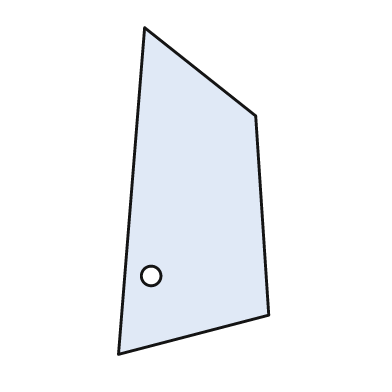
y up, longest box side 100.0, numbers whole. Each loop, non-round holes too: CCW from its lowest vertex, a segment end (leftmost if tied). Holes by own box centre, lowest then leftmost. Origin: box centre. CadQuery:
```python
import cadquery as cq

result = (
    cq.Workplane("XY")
    .moveTo(-23.0, -50.0)
    .lineTo(23.0, -38.0)
    .lineTo(19.0, 23.0)
    .lineTo(-15.0, 50.0)
    .close()
    .moveTo(-13.0, -26.0)
    .circle(3.0)
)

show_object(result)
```